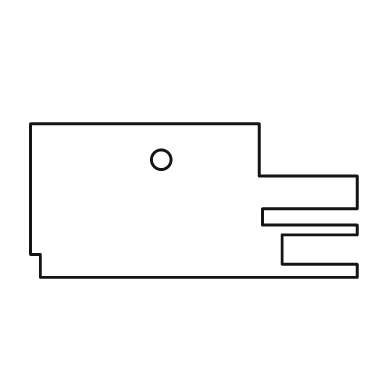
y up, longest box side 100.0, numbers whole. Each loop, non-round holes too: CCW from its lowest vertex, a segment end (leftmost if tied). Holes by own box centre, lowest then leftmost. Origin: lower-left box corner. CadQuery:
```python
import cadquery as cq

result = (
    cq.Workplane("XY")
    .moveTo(3.0, 0.0)
    .lineTo(100.0, 0.0)
    .lineTo(100.0, 4.0)
    .lineTo(77.0, 4.0)
    .lineTo(77.0, 13.0)
    .lineTo(100.0, 13.0)
    .lineTo(100.0, 16.0)
    .lineTo(71.0, 16.0)
    .lineTo(71.0, 21.0)
    .lineTo(100.0, 21.0)
    .lineTo(100.0, 31.0)
    .lineTo(70.0, 31.0)
    .lineTo(70.0, 47.0)
    .lineTo(0.0, 47.0)
    .lineTo(0.0, 7.0)
    .lineTo(3.0, 7.0)
    .close()
    .moveTo(40.0, 36.0)
    .circle(3.0)
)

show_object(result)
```